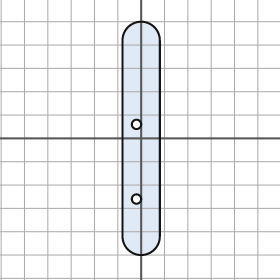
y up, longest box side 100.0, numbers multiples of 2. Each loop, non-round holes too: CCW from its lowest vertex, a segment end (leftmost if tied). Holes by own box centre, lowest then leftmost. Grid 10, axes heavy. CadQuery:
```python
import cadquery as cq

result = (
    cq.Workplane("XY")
    .moveTo(-8.0, -42.0)
    .threePointArc((0.0, -50.0), (8.0, -42.0))
    .lineTo(8.0, 42.0)
    .threePointArc((0.0, 50.0), (-8.0, 42.0))
    .close()
    .moveTo(-2.0, -26.0)
    .circle(2.0)
    .moveTo(-2.0, 6.0)
    .circle(2.0)
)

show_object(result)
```